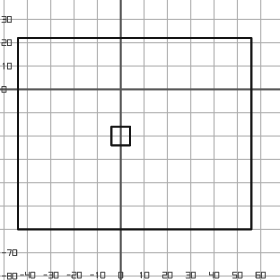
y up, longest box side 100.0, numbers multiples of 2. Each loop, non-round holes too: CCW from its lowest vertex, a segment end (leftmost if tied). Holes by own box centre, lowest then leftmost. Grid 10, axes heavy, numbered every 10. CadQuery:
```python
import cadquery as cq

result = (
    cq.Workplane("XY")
    .moveTo(-44.0, -60.0)
    .lineTo(56.0, -60.0)
    .lineTo(56.0, 22.0)
    .lineTo(-44.0, 22.0)
    .close()
    .moveTo(-4.0, -24.0)
    .lineTo(4.0, -24.0)
    .lineTo(4.0, -16.0)
    .lineTo(-4.0, -16.0)
    .close()
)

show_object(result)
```